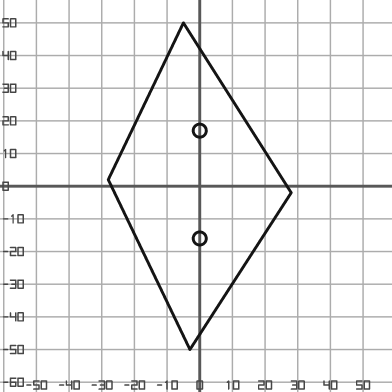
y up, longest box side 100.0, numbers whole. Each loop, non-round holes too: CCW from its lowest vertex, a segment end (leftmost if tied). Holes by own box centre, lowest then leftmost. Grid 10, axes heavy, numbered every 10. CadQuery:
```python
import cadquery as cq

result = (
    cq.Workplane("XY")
    .moveTo(-3.0, -50.0)
    .lineTo(28.0, -2.0)
    .lineTo(-5.0, 50.0)
    .lineTo(-28.0, 2.0)
    .close()
    .moveTo(0.0, -16.0)
    .circle(2.0)
    .moveTo(0.0, 17.0)
    .circle(2.0)
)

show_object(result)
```